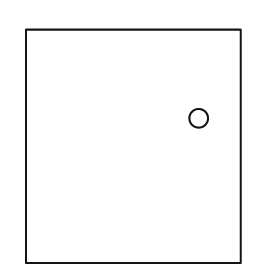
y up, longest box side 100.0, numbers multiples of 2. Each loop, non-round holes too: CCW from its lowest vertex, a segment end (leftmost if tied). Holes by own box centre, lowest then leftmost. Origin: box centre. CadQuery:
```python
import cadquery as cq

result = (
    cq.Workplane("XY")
    .moveTo(-46.0, -50.0)
    .lineTo(46.0, -50.0)
    .lineTo(46.0, 50.0)
    .lineTo(-46.0, 50.0)
    .close()
    .moveTo(28.0, 12.0)
    .circle(4.0)
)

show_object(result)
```